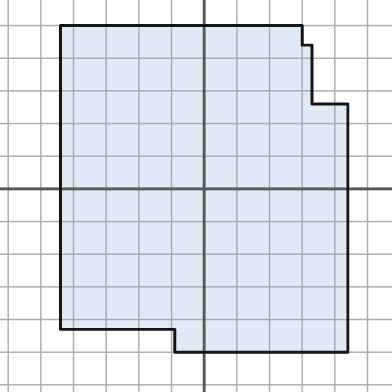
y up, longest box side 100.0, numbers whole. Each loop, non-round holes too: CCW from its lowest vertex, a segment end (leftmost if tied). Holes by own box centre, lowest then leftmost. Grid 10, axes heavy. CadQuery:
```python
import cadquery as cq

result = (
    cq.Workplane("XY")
    .moveTo(-9.0, -50.0)
    .lineTo(44.0, -50.0)
    .lineTo(44.0, 26.0)
    .lineTo(33.0, 26.0)
    .lineTo(33.0, 44.0)
    .lineTo(30.0, 44.0)
    .lineTo(30.0, 50.0)
    .lineTo(-44.0, 50.0)
    .lineTo(-44.0, -43.0)
    .lineTo(-9.0, -43.0)
    .close()
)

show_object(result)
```